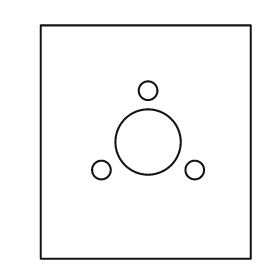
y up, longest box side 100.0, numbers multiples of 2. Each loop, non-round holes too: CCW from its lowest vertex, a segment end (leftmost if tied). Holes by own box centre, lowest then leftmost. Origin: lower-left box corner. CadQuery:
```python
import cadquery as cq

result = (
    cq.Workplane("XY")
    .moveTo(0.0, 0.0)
    .lineTo(90.0, 0.0)
    .lineTo(90.0, 100.0)
    .lineTo(0.0, 100.0)
    .close()
    .moveTo(26.0, 38.0)
    .circle(4.0)
    .moveTo(66.0, 38.0)
    .circle(4.0)
    .moveTo(46.0, 50.0)
    .circle(14.0)
    .moveTo(46.0, 72.0)
    .circle(4.0)
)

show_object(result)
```